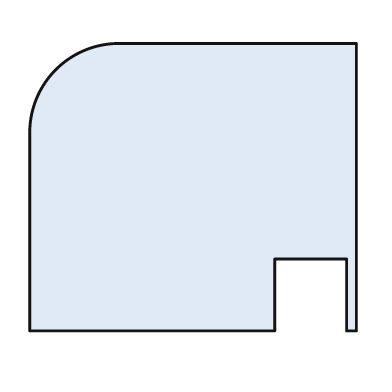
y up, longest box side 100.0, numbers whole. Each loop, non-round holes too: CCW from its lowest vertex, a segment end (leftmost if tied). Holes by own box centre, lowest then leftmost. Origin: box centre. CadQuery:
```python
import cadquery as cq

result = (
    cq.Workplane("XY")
    .moveTo(-50.0, -44.0)
    .lineTo(25.0, -44.0)
    .lineTo(25.0, -22.0)
    .lineTo(47.0, -22.0)
    .lineTo(47.0, -44.0)
    .lineTo(50.0, -44.0)
    .lineTo(50.0, 44.0)
    .lineTo(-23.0, 44.0)
    .threePointArc((-42.0, 36.0), (-50.0, 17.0))
    .close()
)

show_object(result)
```